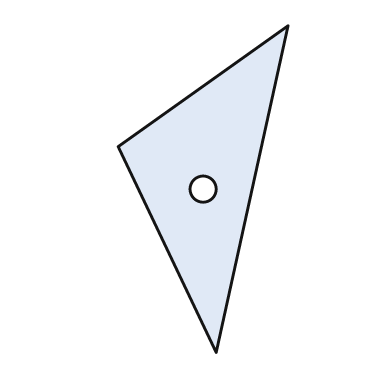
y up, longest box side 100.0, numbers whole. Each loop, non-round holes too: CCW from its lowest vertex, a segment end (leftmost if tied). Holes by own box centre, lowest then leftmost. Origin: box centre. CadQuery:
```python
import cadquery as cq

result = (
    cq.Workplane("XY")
    .moveTo(4.0, -50.0)
    .lineTo(26.0, 50.0)
    .lineTo(-26.0, 13.0)
    .close()
    .moveTo(0.0, 0.0)
    .circle(4.0)
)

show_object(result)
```